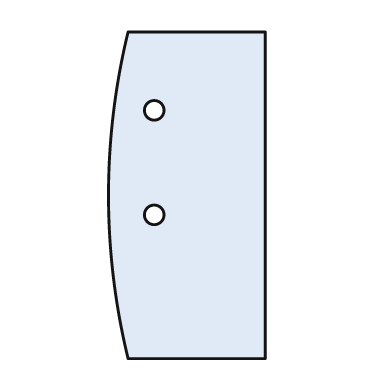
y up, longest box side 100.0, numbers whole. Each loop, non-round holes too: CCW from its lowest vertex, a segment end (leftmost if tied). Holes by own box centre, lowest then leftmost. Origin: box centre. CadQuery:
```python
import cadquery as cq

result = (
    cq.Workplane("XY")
    .moveTo(-18.0, -50.0)
    .lineTo(24.0, -50.0)
    .lineTo(24.0, 50.0)
    .lineTo(-18.0, 50.0)
    .threePointArc((-24.0, 0.0), (-18.0, -50.0))
    .close()
    .moveTo(-10.0, -6.0)
    .circle(3.0)
    .moveTo(-10.0, 26.0)
    .circle(3.0)
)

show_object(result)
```